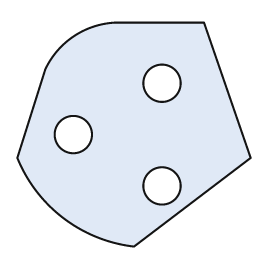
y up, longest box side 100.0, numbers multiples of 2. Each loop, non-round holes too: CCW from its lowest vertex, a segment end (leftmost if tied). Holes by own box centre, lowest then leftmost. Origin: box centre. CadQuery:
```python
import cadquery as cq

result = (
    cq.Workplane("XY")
    .moveTo(0.0, -48.0)
    .lineTo(50.0, -10.0)
    .lineTo(30.0, 48.0)
    .lineTo(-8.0, 48.0)
    .threePointArc((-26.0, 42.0), (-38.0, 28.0))
    .lineTo(-50.0, -10.0)
    .threePointArc((-30.0, -36.0), (0.0, -48.0))
    .close()
    .moveTo(12.0, -22.0)
    .circle(8.0)
    .moveTo(-26.0, 0.0)
    .circle(8.0)
    .moveTo(12.0, 22.0)
    .circle(8.0)
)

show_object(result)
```